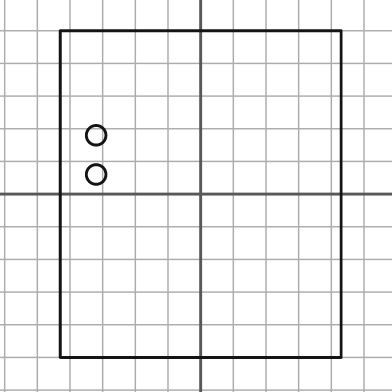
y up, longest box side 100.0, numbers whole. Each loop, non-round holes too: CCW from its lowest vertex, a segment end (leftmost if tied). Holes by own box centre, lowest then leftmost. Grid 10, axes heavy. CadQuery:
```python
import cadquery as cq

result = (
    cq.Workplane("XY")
    .moveTo(-43.0, -50.0)
    .lineTo(43.0, -50.0)
    .lineTo(43.0, 50.0)
    .lineTo(-43.0, 50.0)
    .close()
    .moveTo(-32.0, 6.0)
    .circle(3.0)
    .moveTo(-32.0, 18.0)
    .circle(3.0)
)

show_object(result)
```